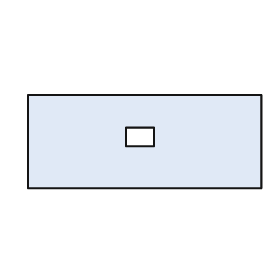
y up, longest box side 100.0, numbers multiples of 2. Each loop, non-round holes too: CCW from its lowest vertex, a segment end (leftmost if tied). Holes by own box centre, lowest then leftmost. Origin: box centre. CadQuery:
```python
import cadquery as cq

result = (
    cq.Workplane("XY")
    .moveTo(-50.0, -20.0)
    .lineTo(50.0, -20.0)
    .lineTo(50.0, 20.0)
    .lineTo(-50.0, 20.0)
    .close()
    .moveTo(-8.0, -2.0)
    .lineTo(4.0, -2.0)
    .lineTo(4.0, 6.0)
    .lineTo(-8.0, 6.0)
    .close()
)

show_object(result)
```